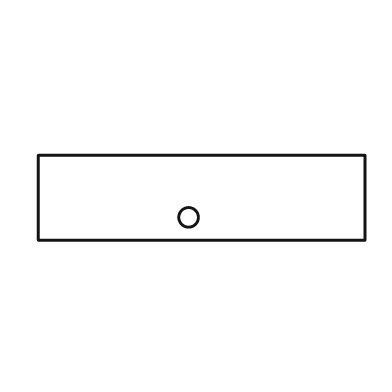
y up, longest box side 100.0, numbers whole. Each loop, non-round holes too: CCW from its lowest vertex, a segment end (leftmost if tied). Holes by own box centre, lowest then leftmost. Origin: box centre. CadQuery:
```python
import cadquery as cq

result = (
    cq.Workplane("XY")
    .moveTo(-50.0, -13.0)
    .lineTo(50.0, -13.0)
    .lineTo(50.0, 13.0)
    .lineTo(-50.0, 13.0)
    .close()
    .moveTo(-4.0, -6.0)
    .circle(3.0)
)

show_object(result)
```